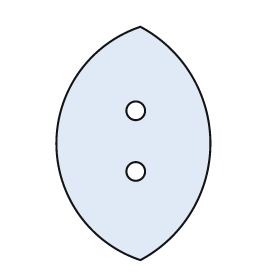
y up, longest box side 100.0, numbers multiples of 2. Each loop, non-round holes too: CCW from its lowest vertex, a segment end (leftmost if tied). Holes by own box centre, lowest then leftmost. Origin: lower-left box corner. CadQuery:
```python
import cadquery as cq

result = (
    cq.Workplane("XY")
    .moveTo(36.0, 0.0)
    .threePointArc((66.0, 50.0), (36.0, 100.0))
    .threePointArc((0.0, 50.0), (36.0, 0.0))
    .close()
    .moveTo(34.0, 38.0)
    .circle(4.0)
    .moveTo(34.0, 64.0)
    .circle(4.0)
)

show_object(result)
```